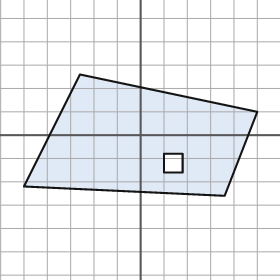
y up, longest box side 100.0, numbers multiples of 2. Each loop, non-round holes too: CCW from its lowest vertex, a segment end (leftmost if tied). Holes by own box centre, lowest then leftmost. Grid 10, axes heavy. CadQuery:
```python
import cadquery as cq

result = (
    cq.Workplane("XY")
    .moveTo(36.0, -26.0)
    .lineTo(50.0, 10.0)
    .lineTo(-26.0, 26.0)
    .lineTo(-50.0, -22.0)
    .close()
    .moveTo(10.0, -16.0)
    .lineTo(18.0, -16.0)
    .lineTo(18.0, -8.0)
    .lineTo(10.0, -8.0)
    .close()
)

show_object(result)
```